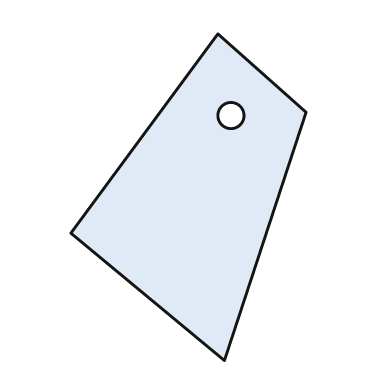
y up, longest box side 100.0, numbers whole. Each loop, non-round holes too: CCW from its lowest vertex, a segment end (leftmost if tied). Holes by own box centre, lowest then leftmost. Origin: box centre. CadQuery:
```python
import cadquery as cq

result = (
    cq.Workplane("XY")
    .moveTo(11.0, -50.0)
    .lineTo(36.0, 26.0)
    .lineTo(9.0, 50.0)
    .lineTo(-36.0, -11.0)
    .close()
    .moveTo(13.0, 25.0)
    .circle(4.0)
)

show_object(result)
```